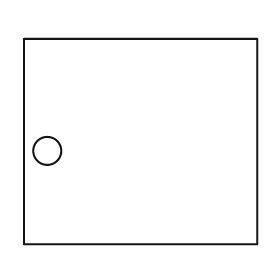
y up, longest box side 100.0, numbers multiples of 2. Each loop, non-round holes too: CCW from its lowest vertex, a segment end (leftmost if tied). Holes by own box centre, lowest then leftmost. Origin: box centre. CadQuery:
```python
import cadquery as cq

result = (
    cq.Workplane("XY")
    .moveTo(-50.0, -44.0)
    .lineTo(50.0, -44.0)
    .lineTo(50.0, 44.0)
    .lineTo(-50.0, 44.0)
    .close()
    .moveTo(-40.0, -4.0)
    .circle(6.0)
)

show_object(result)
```